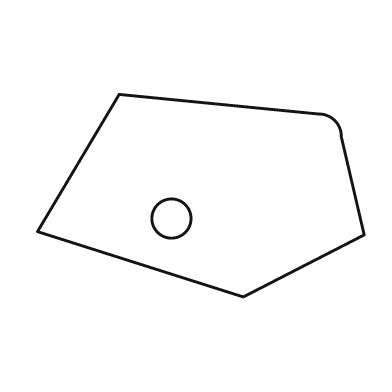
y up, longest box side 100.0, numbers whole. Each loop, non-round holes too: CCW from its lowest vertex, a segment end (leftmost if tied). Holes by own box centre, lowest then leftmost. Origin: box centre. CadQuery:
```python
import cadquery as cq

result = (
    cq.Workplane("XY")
    .moveTo(13.0, -31.0)
    .lineTo(50.0, -12.0)
    .lineTo(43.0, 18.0)
    .threePointArc((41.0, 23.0), (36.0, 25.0))
    .lineTo(-25.0, 31.0)
    .lineTo(-50.0, -11.0)
    .close()
    .moveTo(-9.0, -7.0)
    .circle(6.0)
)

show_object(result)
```